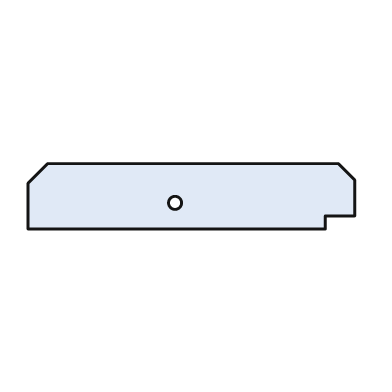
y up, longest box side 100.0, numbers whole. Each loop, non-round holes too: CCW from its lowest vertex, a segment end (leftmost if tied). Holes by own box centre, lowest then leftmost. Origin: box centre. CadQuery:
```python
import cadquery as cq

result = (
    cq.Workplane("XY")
    .moveTo(-50.0, -10.0)
    .lineTo(41.0, -10.0)
    .lineTo(41.0, -6.0)
    .lineTo(50.0, -6.0)
    .lineTo(50.0, 5.0)
    .lineTo(45.0, 10.0)
    .lineTo(-44.0, 10.0)
    .lineTo(-50.0, 4.0)
    .close()
    .moveTo(-5.0, -2.0)
    .circle(2.0)
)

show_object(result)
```